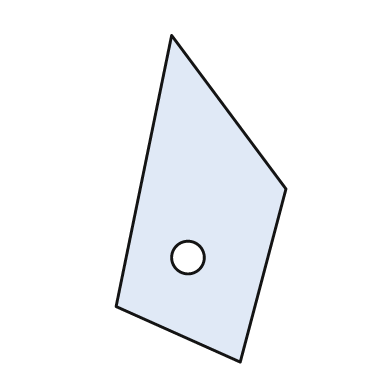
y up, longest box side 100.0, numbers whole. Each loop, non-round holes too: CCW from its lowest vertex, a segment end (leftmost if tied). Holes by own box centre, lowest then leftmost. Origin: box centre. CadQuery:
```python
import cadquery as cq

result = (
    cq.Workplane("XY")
    .moveTo(12.0, -50.0)
    .lineTo(26.0, 3.0)
    .lineTo(-9.0, 50.0)
    .lineTo(-26.0, -33.0)
    .close()
    .moveTo(-4.0, -18.0)
    .circle(5.0)
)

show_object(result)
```